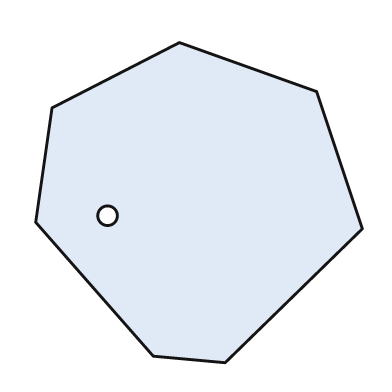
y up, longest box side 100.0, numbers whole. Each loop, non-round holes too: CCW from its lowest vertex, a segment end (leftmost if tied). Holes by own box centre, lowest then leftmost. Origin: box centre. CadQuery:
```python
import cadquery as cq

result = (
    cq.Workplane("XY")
    .moveTo(8.0, -49.0)
    .lineTo(50.0, -8.0)
    .lineTo(36.0, 34.0)
    .lineTo(-6.0, 49.0)
    .lineTo(-45.0, 29.0)
    .lineTo(-50.0, -6.0)
    .lineTo(-14.0, -47.0)
    .close()
    .moveTo(-28.0, -4.0)
    .circle(3.0)
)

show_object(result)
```